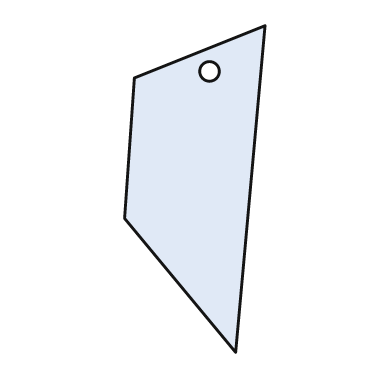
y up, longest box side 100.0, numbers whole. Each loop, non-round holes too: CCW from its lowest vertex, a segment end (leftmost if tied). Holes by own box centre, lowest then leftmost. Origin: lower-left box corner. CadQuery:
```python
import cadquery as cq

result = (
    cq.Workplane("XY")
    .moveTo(34.0, 0.0)
    .lineTo(43.0, 100.0)
    .lineTo(3.0, 84.0)
    .lineTo(0.0, 41.0)
    .close()
    .moveTo(26.0, 86.0)
    .circle(3.0)
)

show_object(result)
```